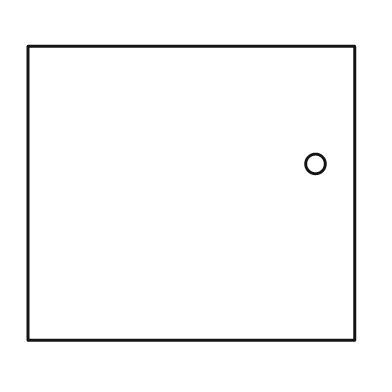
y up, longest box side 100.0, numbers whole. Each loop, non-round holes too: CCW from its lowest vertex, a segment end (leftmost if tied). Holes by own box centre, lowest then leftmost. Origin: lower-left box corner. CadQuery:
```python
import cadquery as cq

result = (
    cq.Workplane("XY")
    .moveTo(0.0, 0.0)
    .lineTo(100.0, 0.0)
    .lineTo(100.0, 90.0)
    .lineTo(0.0, 90.0)
    .close()
    .moveTo(88.0, 54.0)
    .circle(3.0)
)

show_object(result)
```